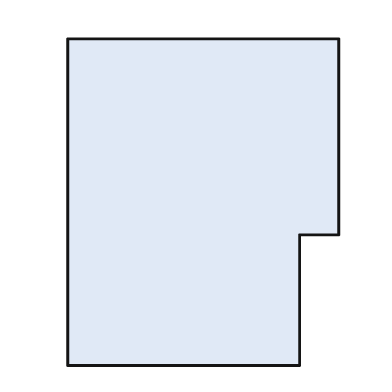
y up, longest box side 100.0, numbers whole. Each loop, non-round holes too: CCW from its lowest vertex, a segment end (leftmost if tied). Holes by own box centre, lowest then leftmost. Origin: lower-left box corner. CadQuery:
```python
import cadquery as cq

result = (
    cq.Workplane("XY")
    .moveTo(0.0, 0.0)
    .lineTo(71.0, 0.0)
    .lineTo(71.0, 40.0)
    .lineTo(83.0, 40.0)
    .lineTo(83.0, 100.0)
    .lineTo(0.0, 100.0)
    .close()
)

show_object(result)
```